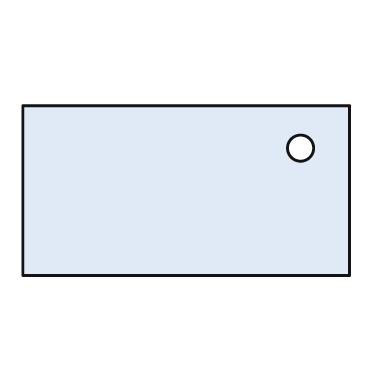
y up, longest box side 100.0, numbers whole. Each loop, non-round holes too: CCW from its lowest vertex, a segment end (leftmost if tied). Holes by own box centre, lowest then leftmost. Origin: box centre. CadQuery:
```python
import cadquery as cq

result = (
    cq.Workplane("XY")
    .moveTo(-50.0, -26.0)
    .lineTo(50.0, -26.0)
    .lineTo(50.0, 26.0)
    .lineTo(-50.0, 26.0)
    .close()
    .moveTo(35.0, 13.0)
    .circle(4.0)
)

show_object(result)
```